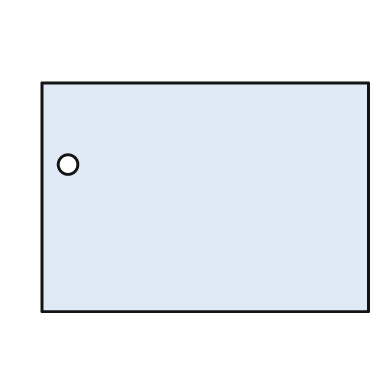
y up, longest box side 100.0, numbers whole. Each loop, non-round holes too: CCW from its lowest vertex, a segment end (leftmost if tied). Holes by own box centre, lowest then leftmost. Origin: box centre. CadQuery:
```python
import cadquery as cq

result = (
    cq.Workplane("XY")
    .moveTo(-50.0, -35.0)
    .lineTo(50.0, -35.0)
    .lineTo(50.0, 35.0)
    .lineTo(-50.0, 35.0)
    .close()
    .moveTo(-42.0, 10.0)
    .circle(3.0)
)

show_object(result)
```